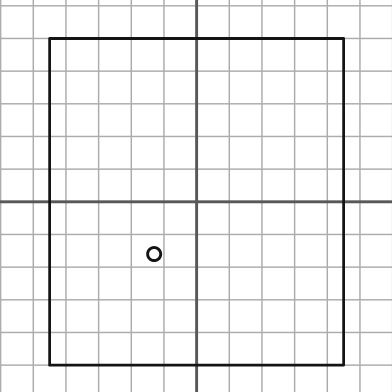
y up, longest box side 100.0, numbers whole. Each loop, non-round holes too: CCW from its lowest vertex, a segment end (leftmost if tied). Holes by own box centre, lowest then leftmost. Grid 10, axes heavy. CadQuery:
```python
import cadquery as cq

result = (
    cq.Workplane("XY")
    .moveTo(-45.0, -50.0)
    .lineTo(45.0, -50.0)
    .lineTo(45.0, 50.0)
    .lineTo(-45.0, 50.0)
    .close()
    .moveTo(-13.0, -16.0)
    .circle(2.0)
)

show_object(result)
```